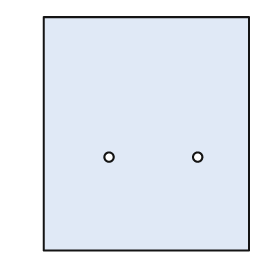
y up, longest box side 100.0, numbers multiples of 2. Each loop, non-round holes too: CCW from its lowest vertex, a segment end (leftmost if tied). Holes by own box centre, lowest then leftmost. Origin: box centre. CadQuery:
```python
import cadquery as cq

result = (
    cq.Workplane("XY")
    .moveTo(-44.0, -50.0)
    .lineTo(44.0, -50.0)
    .lineTo(44.0, 50.0)
    .lineTo(-44.0, 50.0)
    .close()
    .moveTo(-16.0, -10.0)
    .circle(2.0)
    .moveTo(22.0, -10.0)
    .circle(2.0)
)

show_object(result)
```